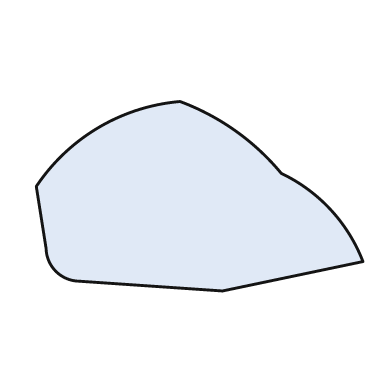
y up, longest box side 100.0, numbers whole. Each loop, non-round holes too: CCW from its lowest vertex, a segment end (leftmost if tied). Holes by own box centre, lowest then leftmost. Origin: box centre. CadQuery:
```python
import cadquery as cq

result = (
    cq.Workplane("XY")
    .moveTo(7.0, -29.0)
    .lineTo(50.0, -20.0)
    .threePointArc((40.0, -4.0), (25.0, 7.0))
    .threePointArc((11.0, 20.0), (-6.0, 29.0))
    .threePointArc((-31.0, 21.0), (-50.0, 3.0))
    .lineTo(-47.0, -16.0)
    .threePointArc((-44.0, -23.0), (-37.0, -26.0))
    .close()
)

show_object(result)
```